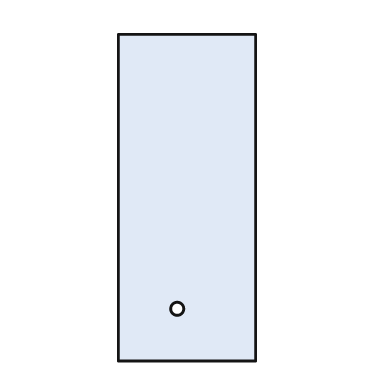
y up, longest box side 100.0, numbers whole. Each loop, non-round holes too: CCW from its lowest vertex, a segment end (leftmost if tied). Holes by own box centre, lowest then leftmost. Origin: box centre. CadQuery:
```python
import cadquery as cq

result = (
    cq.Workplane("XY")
    .moveTo(-21.0, -50.0)
    .lineTo(21.0, -50.0)
    .lineTo(21.0, 50.0)
    .lineTo(-21.0, 50.0)
    .close()
    .moveTo(-3.0, -34.0)
    .circle(2.0)
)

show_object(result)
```